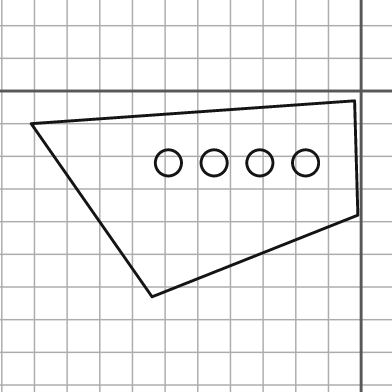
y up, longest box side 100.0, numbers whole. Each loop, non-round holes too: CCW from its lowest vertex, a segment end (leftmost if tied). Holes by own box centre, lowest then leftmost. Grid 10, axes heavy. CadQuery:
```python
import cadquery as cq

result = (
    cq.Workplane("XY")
    .moveTo(-64.0, -63.0)
    .lineTo(-1.0, -38.0)
    .lineTo(-2.0, -3.0)
    .lineTo(-101.0, -10.0)
    .close()
    .moveTo(-59.0, -22.0)
    .circle(4.0)
    .moveTo(-45.0, -22.0)
    .circle(4.0)
    .moveTo(-31.0, -22.0)
    .circle(4.0)
    .moveTo(-17.0, -22.0)
    .circle(4.0)
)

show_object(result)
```